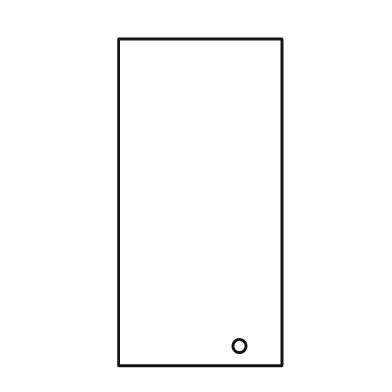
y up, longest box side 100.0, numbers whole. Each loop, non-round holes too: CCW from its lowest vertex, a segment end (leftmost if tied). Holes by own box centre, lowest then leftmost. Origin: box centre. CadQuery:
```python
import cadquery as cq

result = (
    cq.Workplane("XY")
    .moveTo(-25.0, -50.0)
    .lineTo(25.0, -50.0)
    .lineTo(25.0, 50.0)
    .lineTo(-25.0, 50.0)
    .close()
    .moveTo(12.0, -44.0)
    .circle(2.0)
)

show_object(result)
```